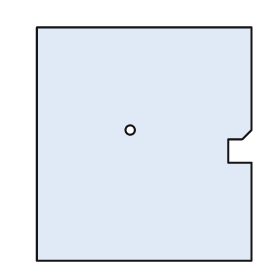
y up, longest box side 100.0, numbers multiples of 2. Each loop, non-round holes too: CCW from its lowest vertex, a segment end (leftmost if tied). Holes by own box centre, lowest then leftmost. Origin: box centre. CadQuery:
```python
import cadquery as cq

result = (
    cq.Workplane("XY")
    .moveTo(-46.0, -50.0)
    .lineTo(46.0, -50.0)
    .lineTo(46.0, -8.0)
    .lineTo(36.0, -8.0)
    .lineTo(36.0, 2.0)
    .lineTo(42.0, 2.0)
    .lineTo(46.0, 6.0)
    .lineTo(46.0, 50.0)
    .lineTo(-46.0, 50.0)
    .close()
    .moveTo(-6.0, 6.0)
    .circle(2.0)
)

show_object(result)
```